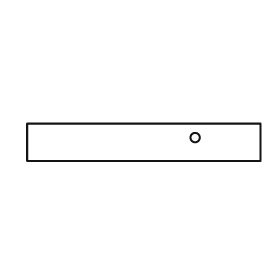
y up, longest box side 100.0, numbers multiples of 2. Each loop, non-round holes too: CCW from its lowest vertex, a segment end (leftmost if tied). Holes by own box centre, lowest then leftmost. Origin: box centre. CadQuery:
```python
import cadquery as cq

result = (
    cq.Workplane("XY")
    .moveTo(-50.0, -8.0)
    .lineTo(50.0, -8.0)
    .lineTo(50.0, 8.0)
    .lineTo(-50.0, 8.0)
    .close()
    .moveTo(22.0, 2.0)
    .circle(2.0)
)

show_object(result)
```